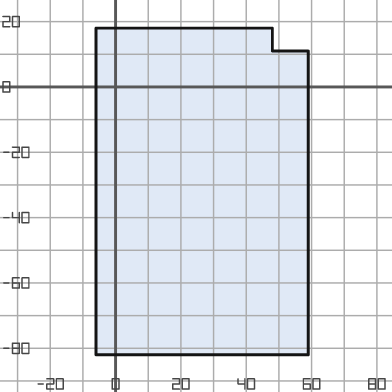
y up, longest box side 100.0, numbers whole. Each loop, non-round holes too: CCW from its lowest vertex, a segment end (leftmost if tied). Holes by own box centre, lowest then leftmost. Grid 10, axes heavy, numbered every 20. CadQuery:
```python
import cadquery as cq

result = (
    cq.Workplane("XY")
    .moveTo(-6.0, -82.0)
    .lineTo(59.0, -82.0)
    .lineTo(59.0, 11.0)
    .lineTo(48.0, 11.0)
    .lineTo(48.0, 18.0)
    .lineTo(-6.0, 18.0)
    .close()
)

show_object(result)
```